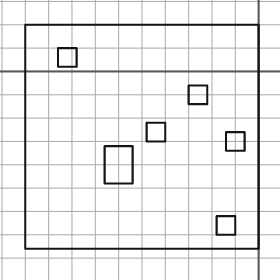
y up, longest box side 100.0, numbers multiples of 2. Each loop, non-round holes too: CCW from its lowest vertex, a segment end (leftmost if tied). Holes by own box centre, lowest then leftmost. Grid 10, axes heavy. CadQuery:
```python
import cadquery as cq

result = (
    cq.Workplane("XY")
    .moveTo(-100.0, -76.0)
    .lineTo(0.0, -76.0)
    .lineTo(0.0, 20.0)
    .lineTo(-100.0, 20.0)
    .close()
    .moveTo(-18.0, -70.0)
    .lineTo(-10.0, -70.0)
    .lineTo(-10.0, -62.0)
    .lineTo(-18.0, -62.0)
    .close()
    .moveTo(-66.0, -48.0)
    .lineTo(-54.0, -48.0)
    .lineTo(-54.0, -32.0)
    .lineTo(-66.0, -32.0)
    .close()
    .moveTo(-14.0, -34.0)
    .lineTo(-6.0, -34.0)
    .lineTo(-6.0, -26.0)
    .lineTo(-14.0, -26.0)
    .close()
    .moveTo(-48.0, -30.0)
    .lineTo(-40.0, -30.0)
    .lineTo(-40.0, -22.0)
    .lineTo(-48.0, -22.0)
    .close()
    .moveTo(-30.0, -14.0)
    .lineTo(-22.0, -14.0)
    .lineTo(-22.0, -6.0)
    .lineTo(-30.0, -6.0)
    .close()
    .moveTo(-86.0, 2.0)
    .lineTo(-78.0, 2.0)
    .lineTo(-78.0, 10.0)
    .lineTo(-86.0, 10.0)
    .close()
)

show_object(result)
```